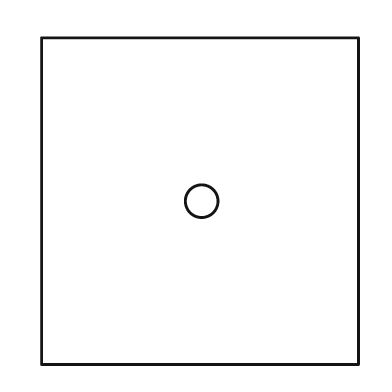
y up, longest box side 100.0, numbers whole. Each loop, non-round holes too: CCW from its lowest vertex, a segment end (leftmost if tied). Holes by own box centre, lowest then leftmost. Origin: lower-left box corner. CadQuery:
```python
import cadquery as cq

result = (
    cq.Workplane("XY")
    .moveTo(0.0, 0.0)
    .lineTo(97.0, 0.0)
    .lineTo(97.0, 100.0)
    .lineTo(0.0, 100.0)
    .close()
    .moveTo(49.0, 50.0)
    .circle(5.0)
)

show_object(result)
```